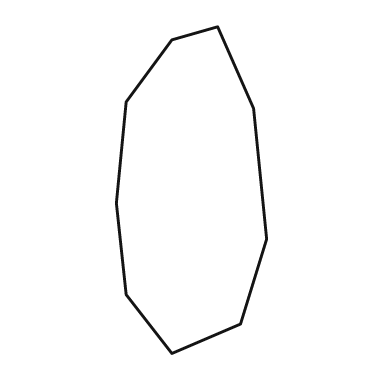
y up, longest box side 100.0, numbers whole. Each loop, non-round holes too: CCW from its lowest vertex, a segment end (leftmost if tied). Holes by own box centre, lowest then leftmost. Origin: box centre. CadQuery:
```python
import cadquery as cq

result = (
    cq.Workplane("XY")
    .moveTo(-6.0, -50.0)
    .lineTo(15.0, -41.0)
    .lineTo(23.0, -15.0)
    .lineTo(19.0, 25.0)
    .lineTo(8.0, 50.0)
    .lineTo(-6.0, 46.0)
    .lineTo(-20.0, 27.0)
    .lineTo(-23.0, -4.0)
    .lineTo(-20.0, -32.0)
    .close()
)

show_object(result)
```